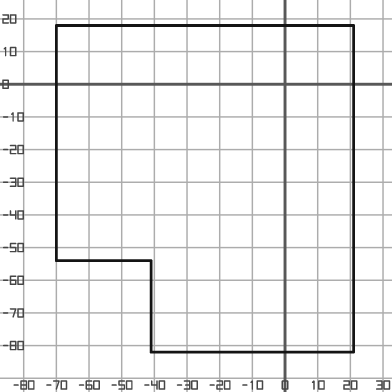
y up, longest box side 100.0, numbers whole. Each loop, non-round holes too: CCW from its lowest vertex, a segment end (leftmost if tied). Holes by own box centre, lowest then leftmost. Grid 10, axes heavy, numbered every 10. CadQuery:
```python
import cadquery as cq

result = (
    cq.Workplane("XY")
    .moveTo(-41.0, -82.0)
    .lineTo(21.0, -82.0)
    .lineTo(21.0, 18.0)
    .lineTo(-70.0, 18.0)
    .lineTo(-70.0, -54.0)
    .lineTo(-41.0, -54.0)
    .close()
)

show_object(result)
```